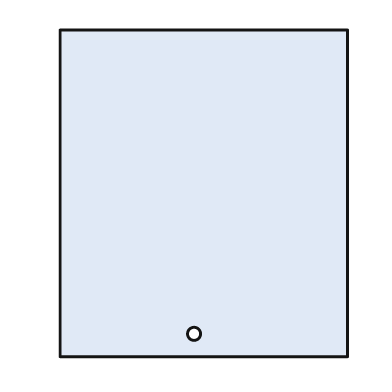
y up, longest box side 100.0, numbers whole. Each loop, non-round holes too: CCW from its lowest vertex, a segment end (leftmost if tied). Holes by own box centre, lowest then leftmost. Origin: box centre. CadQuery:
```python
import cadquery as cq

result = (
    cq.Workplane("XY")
    .moveTo(-44.0, -50.0)
    .lineTo(44.0, -50.0)
    .lineTo(44.0, 50.0)
    .lineTo(-44.0, 50.0)
    .close()
    .moveTo(-3.0, -43.0)
    .circle(2.0)
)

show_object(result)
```